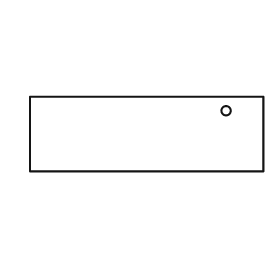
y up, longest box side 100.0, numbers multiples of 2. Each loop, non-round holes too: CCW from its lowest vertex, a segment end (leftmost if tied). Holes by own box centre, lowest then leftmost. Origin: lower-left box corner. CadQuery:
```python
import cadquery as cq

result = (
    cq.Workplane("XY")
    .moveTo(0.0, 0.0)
    .lineTo(100.0, 0.0)
    .lineTo(100.0, 32.0)
    .lineTo(0.0, 32.0)
    .close()
    .moveTo(84.0, 26.0)
    .circle(2.0)
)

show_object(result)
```